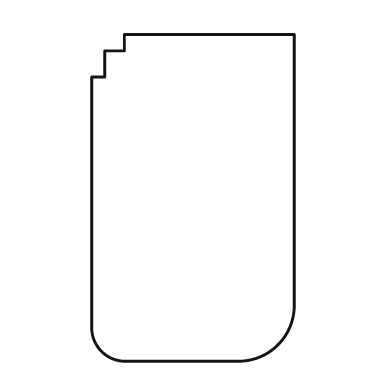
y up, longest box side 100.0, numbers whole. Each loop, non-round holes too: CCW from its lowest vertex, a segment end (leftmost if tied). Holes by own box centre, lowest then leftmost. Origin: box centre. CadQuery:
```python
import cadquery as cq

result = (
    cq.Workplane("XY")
    .moveTo(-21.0, -50.0)
    .lineTo(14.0, -50.0)
    .threePointArc((26.0, -45.0), (31.0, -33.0))
    .lineTo(31.0, 50.0)
    .lineTo(-21.0, 50.0)
    .lineTo(-21.0, 45.0)
    .lineTo(-27.0, 45.0)
    .lineTo(-27.0, 37.0)
    .lineTo(-31.0, 37.0)
    .lineTo(-31.0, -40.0)
    .threePointArc((-28.0, -47.0), (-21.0, -50.0))
    .close()
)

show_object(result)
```